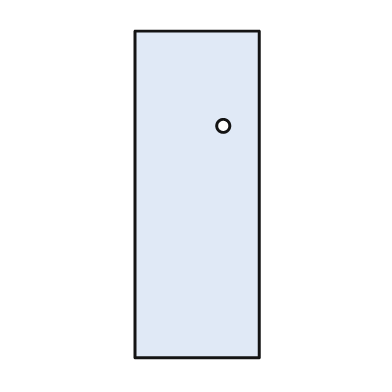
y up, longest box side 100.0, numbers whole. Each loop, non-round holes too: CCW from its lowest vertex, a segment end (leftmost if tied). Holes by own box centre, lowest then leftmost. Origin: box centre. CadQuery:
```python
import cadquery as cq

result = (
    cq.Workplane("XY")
    .moveTo(-19.0, -50.0)
    .lineTo(19.0, -50.0)
    .lineTo(19.0, 50.0)
    .lineTo(-19.0, 50.0)
    .close()
    .moveTo(8.0, 21.0)
    .circle(2.0)
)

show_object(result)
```